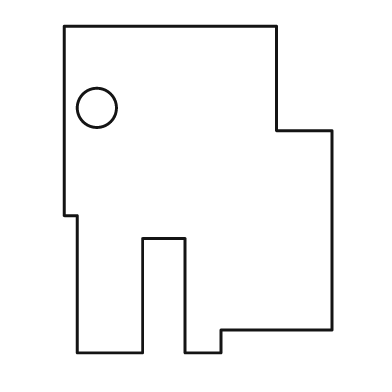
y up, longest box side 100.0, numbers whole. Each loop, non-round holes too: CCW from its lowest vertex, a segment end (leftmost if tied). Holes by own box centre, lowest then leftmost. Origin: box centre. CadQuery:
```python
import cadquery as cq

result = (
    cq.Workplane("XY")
    .moveTo(-37.0, -50.0)
    .lineTo(-17.0, -50.0)
    .lineTo(-17.0, -15.0)
    .lineTo(-4.0, -15.0)
    .lineTo(-4.0, -50.0)
    .lineTo(7.0, -50.0)
    .lineTo(7.0, -43.0)
    .lineTo(41.0, -43.0)
    .lineTo(41.0, 18.0)
    .lineTo(24.0, 18.0)
    .lineTo(24.0, 50.0)
    .lineTo(-41.0, 50.0)
    .lineTo(-41.0, -8.0)
    .lineTo(-37.0, -8.0)
    .close()
    .moveTo(-31.0, 25.0)
    .circle(6.0)
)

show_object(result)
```